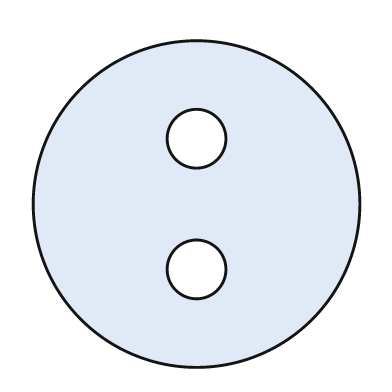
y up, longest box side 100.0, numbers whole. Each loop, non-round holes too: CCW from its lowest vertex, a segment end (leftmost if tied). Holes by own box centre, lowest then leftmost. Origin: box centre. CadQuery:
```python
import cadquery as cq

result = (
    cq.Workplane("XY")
    .moveTo(0.0, 0.0)
    .circle(50.0)
    .moveTo(0.0, -20.0)
    .circle(9.0)
    .moveTo(0.0, 20.0)
    .circle(9.0)
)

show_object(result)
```